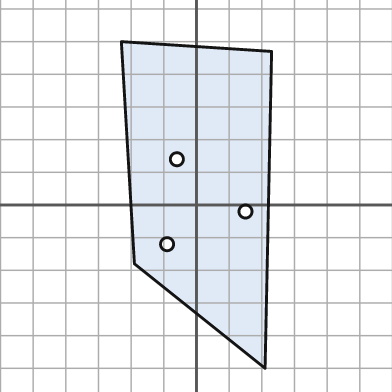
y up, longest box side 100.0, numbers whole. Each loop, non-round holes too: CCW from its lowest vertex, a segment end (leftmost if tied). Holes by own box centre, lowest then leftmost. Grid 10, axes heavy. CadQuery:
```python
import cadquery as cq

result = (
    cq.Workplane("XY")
    .moveTo(21.0, -50.0)
    .lineTo(23.0, 47.0)
    .lineTo(-23.0, 50.0)
    .lineTo(-19.0, -18.0)
    .close()
    .moveTo(-9.0, -12.0)
    .circle(2.0)
    .moveTo(15.0, -2.0)
    .circle(2.0)
    .moveTo(-6.0, 14.0)
    .circle(2.0)
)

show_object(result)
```